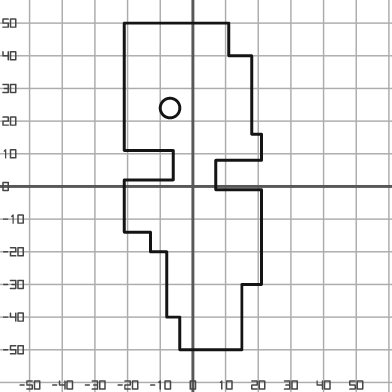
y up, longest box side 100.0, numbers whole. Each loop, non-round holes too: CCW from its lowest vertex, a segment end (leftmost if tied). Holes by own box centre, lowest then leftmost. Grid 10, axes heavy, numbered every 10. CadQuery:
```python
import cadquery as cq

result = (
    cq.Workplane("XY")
    .moveTo(-4.0, -50.0)
    .lineTo(15.0, -50.0)
    .lineTo(15.0, -30.0)
    .lineTo(21.0, -30.0)
    .lineTo(21.0, -1.0)
    .lineTo(7.0, -1.0)
    .lineTo(7.0, 8.0)
    .lineTo(21.0, 8.0)
    .lineTo(21.0, 16.0)
    .lineTo(18.0, 16.0)
    .lineTo(18.0, 40.0)
    .lineTo(11.0, 40.0)
    .lineTo(11.0, 50.0)
    .lineTo(-21.0, 50.0)
    .lineTo(-21.0, 11.0)
    .lineTo(-6.0, 11.0)
    .lineTo(-6.0, 2.0)
    .lineTo(-21.0, 2.0)
    .lineTo(-21.0, -14.0)
    .lineTo(-13.0, -14.0)
    .lineTo(-13.0, -20.0)
    .lineTo(-8.0, -20.0)
    .lineTo(-8.0, -40.0)
    .lineTo(-4.0, -40.0)
    .close()
    .moveTo(-7.0, 24.0)
    .circle(3.0)
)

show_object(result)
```